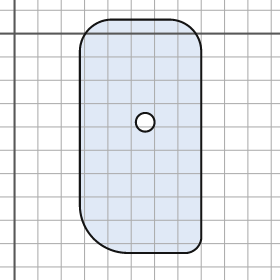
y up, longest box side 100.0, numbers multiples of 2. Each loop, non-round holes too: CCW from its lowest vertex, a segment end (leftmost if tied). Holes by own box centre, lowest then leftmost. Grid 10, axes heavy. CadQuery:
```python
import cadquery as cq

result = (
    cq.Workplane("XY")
    .moveTo(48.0, -94.0)
    .lineTo(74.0, -94.0)
    .threePointArc((78.0, -92.0), (80.0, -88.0))
    .lineTo(80.0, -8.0)
    .threePointArc((76.0, 2.0), (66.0, 6.0))
    .lineTo(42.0, 6.0)
    .threePointArc((32.0, 2.0), (28.0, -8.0))
    .lineTo(28.0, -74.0)
    .threePointArc((34.0, -88.0), (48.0, -94.0))
    .close()
    .moveTo(56.0, -38.0)
    .circle(4.0)
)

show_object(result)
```